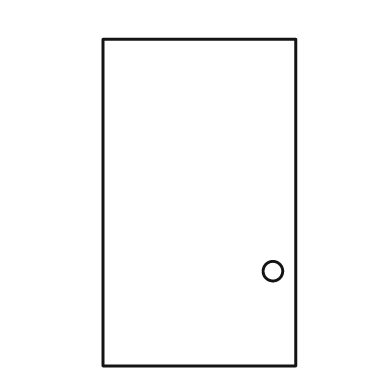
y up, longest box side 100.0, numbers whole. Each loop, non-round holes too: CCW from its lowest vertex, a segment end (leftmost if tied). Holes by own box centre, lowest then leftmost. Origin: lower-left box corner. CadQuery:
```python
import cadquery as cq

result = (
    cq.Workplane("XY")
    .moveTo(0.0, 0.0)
    .lineTo(59.0, 0.0)
    .lineTo(59.0, 100.0)
    .lineTo(0.0, 100.0)
    .close()
    .moveTo(52.0, 29.0)
    .circle(3.0)
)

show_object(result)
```